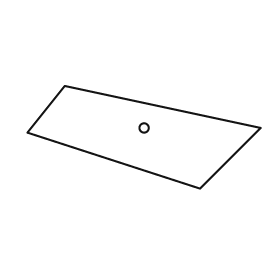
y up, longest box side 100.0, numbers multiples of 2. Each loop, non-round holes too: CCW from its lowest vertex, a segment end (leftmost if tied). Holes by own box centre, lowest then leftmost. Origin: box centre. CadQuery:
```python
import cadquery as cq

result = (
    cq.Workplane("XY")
    .moveTo(24.0, -22.0)
    .lineTo(50.0, 4.0)
    .lineTo(-34.0, 22.0)
    .lineTo(-50.0, 2.0)
    .close()
    .moveTo(0.0, 4.0)
    .circle(2.0)
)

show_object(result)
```